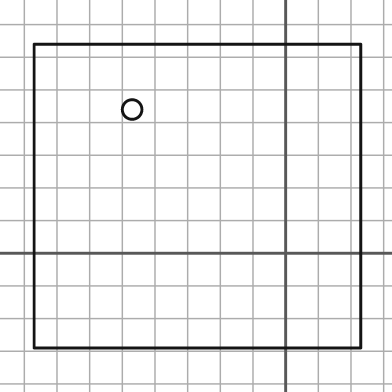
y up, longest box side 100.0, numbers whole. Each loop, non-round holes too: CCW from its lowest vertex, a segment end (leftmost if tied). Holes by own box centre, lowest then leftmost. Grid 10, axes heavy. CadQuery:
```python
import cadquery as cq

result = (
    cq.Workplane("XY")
    .moveTo(-77.0, -29.0)
    .lineTo(23.0, -29.0)
    .lineTo(23.0, 64.0)
    .lineTo(-77.0, 64.0)
    .close()
    .moveTo(-47.0, 44.0)
    .circle(3.0)
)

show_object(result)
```